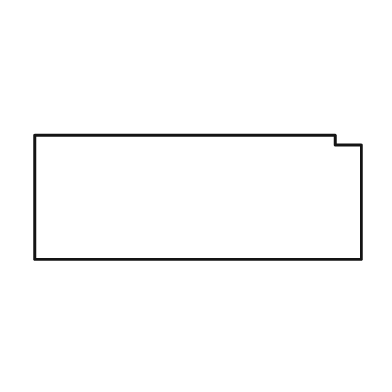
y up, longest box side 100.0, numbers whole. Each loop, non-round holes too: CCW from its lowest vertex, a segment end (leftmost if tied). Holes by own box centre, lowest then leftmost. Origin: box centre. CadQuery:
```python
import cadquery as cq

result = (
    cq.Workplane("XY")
    .moveTo(-50.0, -19.0)
    .lineTo(50.0, -19.0)
    .lineTo(50.0, 16.0)
    .lineTo(42.0, 16.0)
    .lineTo(42.0, 19.0)
    .lineTo(-50.0, 19.0)
    .close()
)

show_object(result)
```